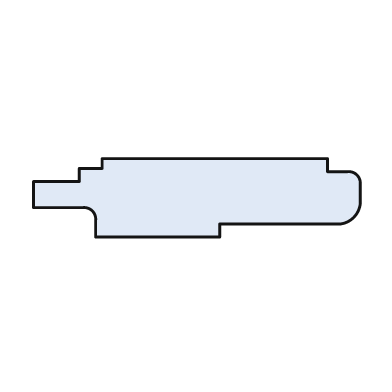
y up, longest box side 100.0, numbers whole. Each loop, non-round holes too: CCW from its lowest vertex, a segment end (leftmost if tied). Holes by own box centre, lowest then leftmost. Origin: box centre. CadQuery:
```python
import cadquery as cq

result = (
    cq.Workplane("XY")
    .moveTo(-31.0, -12.0)
    .lineTo(7.0, -12.0)
    .lineTo(7.0, -8.0)
    .lineTo(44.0, -8.0)
    .threePointArc((48.0, -6.0), (50.0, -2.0))
    .lineTo(50.0, 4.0)
    .threePointArc((49.0, 7.0), (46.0, 8.0))
    .lineTo(40.0, 8.0)
    .lineTo(40.0, 12.0)
    .lineTo(-29.0, 12.0)
    .lineTo(-29.0, 9.0)
    .lineTo(-36.0, 9.0)
    .lineTo(-36.0, 5.0)
    .lineTo(-50.0, 5.0)
    .lineTo(-50.0, -3.0)
    .lineTo(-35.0, -3.0)
    .threePointArc((-32.0, -4.0), (-31.0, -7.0))
    .close()
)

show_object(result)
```